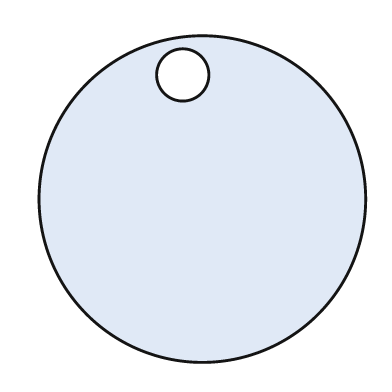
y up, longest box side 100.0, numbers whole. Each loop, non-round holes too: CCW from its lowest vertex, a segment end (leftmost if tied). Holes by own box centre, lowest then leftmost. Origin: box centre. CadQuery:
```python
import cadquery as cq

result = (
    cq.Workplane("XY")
    .moveTo(0.0, 0.0)
    .circle(50.0)
    .moveTo(-6.0, 38.0)
    .circle(8.0)
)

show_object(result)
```